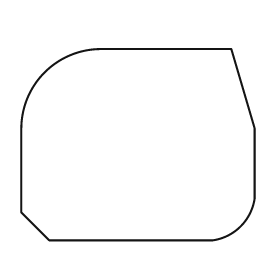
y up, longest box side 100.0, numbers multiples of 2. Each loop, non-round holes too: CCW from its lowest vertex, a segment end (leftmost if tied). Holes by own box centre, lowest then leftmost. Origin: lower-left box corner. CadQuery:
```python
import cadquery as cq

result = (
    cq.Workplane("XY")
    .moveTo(12.0, 0.0)
    .lineTo(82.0, 0.0)
    .threePointArc((94.0, 6.0), (100.0, 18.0))
    .lineTo(100.0, 48.0)
    .lineTo(90.0, 82.0)
    .lineTo(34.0, 82.0)
    .threePointArc((10.0, 72.0), (0.0, 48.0))
    .lineTo(0.0, 12.0)
    .close()
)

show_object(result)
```